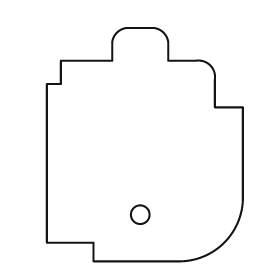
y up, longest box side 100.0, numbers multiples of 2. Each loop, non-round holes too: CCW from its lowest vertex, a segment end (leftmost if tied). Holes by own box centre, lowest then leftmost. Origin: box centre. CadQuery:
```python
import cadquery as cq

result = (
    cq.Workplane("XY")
    .moveTo(-22.0, -50.0)
    .lineTo(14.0, -50.0)
    .threePointArc((34.0, -42.0), (42.0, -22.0))
    .lineTo(42.0, 16.0)
    .lineTo(30.0, 16.0)
    .lineTo(30.0, 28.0)
    .threePointArc((28.0, 34.0), (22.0, 36.0))
    .lineTo(10.0, 36.0)
    .lineTo(10.0, 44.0)
    .threePointArc((8.0, 48.0), (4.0, 50.0))
    .lineTo(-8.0, 50.0)
    .threePointArc((-12.0, 48.0), (-14.0, 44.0))
    .lineTo(-14.0, 36.0)
    .lineTo(-36.0, 36.0)
    .lineTo(-36.0, 26.0)
    .lineTo(-42.0, 26.0)
    .lineTo(-42.0, -42.0)
    .lineTo(-22.0, -42.0)
    .close()
    .moveTo(-2.0, -30.0)
    .circle(4.0)
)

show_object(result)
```